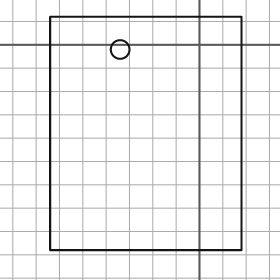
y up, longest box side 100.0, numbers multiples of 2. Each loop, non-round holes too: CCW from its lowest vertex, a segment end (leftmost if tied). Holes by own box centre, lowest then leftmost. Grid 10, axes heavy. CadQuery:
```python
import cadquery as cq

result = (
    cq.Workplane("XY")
    .moveTo(-64.0, -88.0)
    .lineTo(18.0, -88.0)
    .lineTo(18.0, 12.0)
    .lineTo(-64.0, 12.0)
    .close()
    .moveTo(-34.0, -2.0)
    .circle(4.0)
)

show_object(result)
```